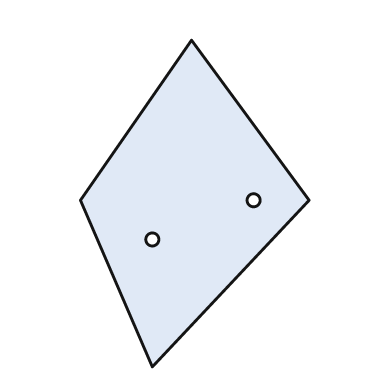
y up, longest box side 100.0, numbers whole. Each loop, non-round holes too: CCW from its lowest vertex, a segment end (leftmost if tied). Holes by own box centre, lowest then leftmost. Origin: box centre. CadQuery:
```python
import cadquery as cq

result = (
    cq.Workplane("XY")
    .moveTo(-13.0, -50.0)
    .lineTo(35.0, 1.0)
    .lineTo(-1.0, 50.0)
    .lineTo(-35.0, 1.0)
    .close()
    .moveTo(-13.0, -11.0)
    .circle(2.0)
    .moveTo(18.0, 1.0)
    .circle(2.0)
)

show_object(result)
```